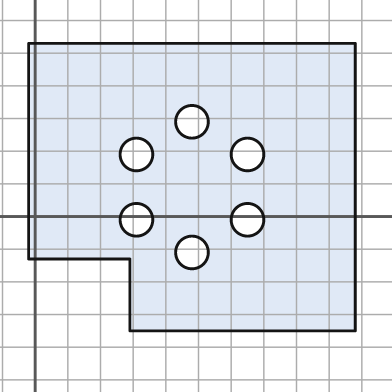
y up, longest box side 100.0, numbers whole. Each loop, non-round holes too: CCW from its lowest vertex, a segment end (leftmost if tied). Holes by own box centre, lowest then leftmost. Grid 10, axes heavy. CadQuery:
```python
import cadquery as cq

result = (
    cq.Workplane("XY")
    .moveTo(29.0, -35.0)
    .lineTo(98.0, -35.0)
    .lineTo(98.0, 53.0)
    .lineTo(-2.0, 53.0)
    .lineTo(-2.0, -13.0)
    .lineTo(29.0, -13.0)
    .close()
    .moveTo(48.0, -11.0)
    .circle(5.0)
    .moveTo(31.0, -1.0)
    .circle(5.0)
    .moveTo(65.0, -1.0)
    .circle(5.0)
    .moveTo(31.0, 19.0)
    .circle(5.0)
    .moveTo(65.0, 19.0)
    .circle(5.0)
    .moveTo(48.0, 29.0)
    .circle(5.0)
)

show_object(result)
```